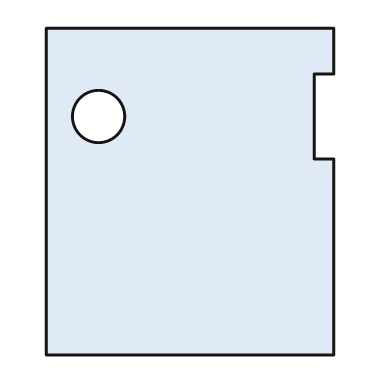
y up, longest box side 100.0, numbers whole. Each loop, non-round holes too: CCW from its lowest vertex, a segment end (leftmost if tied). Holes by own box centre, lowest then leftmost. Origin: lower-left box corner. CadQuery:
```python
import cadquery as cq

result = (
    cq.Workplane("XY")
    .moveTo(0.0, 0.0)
    .lineTo(88.0, 0.0)
    .lineTo(88.0, 60.0)
    .lineTo(82.0, 60.0)
    .lineTo(82.0, 86.0)
    .lineTo(88.0, 86.0)
    .lineTo(88.0, 100.0)
    .lineTo(0.0, 100.0)
    .close()
    .moveTo(16.0, 73.0)
    .circle(8.0)
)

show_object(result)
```